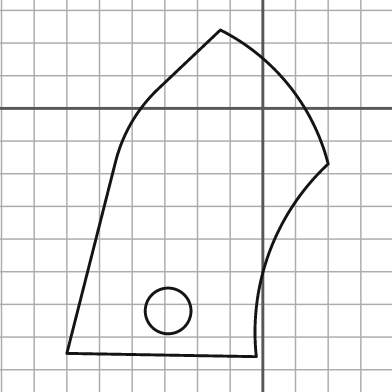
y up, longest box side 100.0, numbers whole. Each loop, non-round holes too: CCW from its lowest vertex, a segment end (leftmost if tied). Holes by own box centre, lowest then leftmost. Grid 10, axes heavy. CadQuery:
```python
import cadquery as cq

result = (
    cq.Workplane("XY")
    .moveTo(-2.0, -76.0)
    .threePointArc((2.0, -44.0), (20.0, -17.0))
    .threePointArc((8.0, 7.0), (-13.0, 24.0))
    .lineTo(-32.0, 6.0)
    .threePointArc((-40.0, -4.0), (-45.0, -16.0))
    .lineTo(-60.0, -75.0)
    .close()
    .moveTo(-29.0, -62.0)
    .circle(7.0)
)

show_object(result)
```